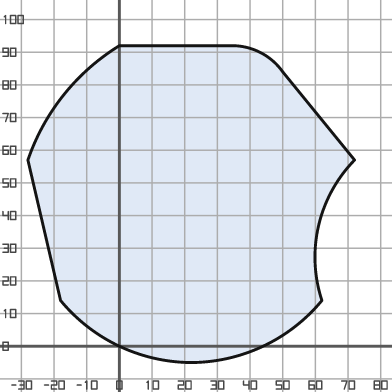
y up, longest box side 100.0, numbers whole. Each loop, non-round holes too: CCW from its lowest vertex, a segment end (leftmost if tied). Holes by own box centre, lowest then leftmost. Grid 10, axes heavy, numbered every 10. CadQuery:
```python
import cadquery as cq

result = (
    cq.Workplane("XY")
    .moveTo(22.0, -5.0)
    .threePointArc((44.0, 0.0), (62.0, 14.0))
    .threePointArc((61.0, 37.0), (72.0, 57.0))
    .lineTo(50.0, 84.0)
    .threePointArc((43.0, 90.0), (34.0, 92.0))
    .lineTo(0.0, 92.0)
    .threePointArc((-17.0, 77.0), (-28.0, 57.0))
    .lineTo(-18.0, 14.0)
    .threePointArc((0.0, 0.0), (22.0, -5.0))
    .close()
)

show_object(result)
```